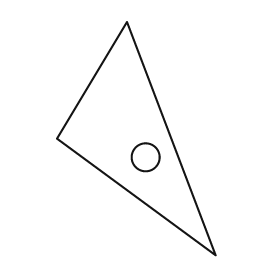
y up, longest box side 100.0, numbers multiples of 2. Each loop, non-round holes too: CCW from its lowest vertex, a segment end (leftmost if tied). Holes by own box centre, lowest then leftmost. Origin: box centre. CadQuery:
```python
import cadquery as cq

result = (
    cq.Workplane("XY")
    .moveTo(34.0, -50.0)
    .lineTo(-4.0, 50.0)
    .lineTo(-34.0, 0.0)
    .close()
    .moveTo(4.0, -8.0)
    .circle(6.0)
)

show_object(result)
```